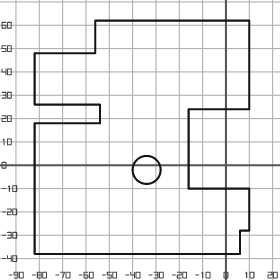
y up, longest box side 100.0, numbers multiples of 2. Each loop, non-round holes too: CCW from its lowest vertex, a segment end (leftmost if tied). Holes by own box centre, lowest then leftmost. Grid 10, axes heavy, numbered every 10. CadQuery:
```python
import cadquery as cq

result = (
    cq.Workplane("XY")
    .moveTo(-82.0, -38.0)
    .lineTo(6.0, -38.0)
    .lineTo(6.0, -28.0)
    .lineTo(10.0, -28.0)
    .lineTo(10.0, -10.0)
    .lineTo(-16.0, -10.0)
    .lineTo(-16.0, 24.0)
    .lineTo(10.0, 24.0)
    .lineTo(10.0, 62.0)
    .lineTo(-56.0, 62.0)
    .lineTo(-56.0, 48.0)
    .lineTo(-82.0, 48.0)
    .lineTo(-82.0, 26.0)
    .lineTo(-54.0, 26.0)
    .lineTo(-54.0, 18.0)
    .lineTo(-82.0, 18.0)
    .close()
    .moveTo(-34.0, -2.0)
    .circle(6.0)
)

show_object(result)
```